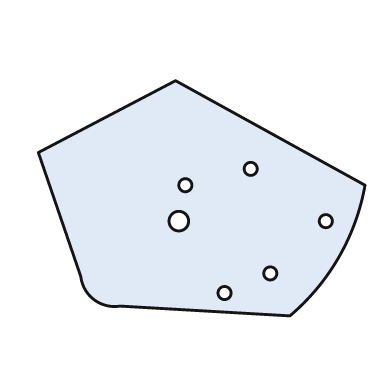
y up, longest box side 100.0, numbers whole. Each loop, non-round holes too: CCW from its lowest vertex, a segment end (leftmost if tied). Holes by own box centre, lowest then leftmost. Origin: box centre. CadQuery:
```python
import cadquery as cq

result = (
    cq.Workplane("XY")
    .moveTo(27.0, -36.0)
    .threePointArc((42.0, -18.0), (50.0, 4.0))
    .lineTo(-8.0, 36.0)
    .lineTo(-50.0, 14.0)
    .lineTo(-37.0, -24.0)
    .threePointArc((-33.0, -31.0), (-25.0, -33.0))
    .close()
    .moveTo(7.0, -29.0)
    .circle(2.0)
    .moveTo(21.0, -23.0)
    .circle(2.0)
    .moveTo(-7.0, -7.0)
    .circle(3.0)
    .moveTo(38.0, -7.0)
    .circle(2.0)
    .moveTo(-5.0, 4.0)
    .circle(2.0)
    .moveTo(15.0, 9.0)
    .circle(2.0)
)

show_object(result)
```